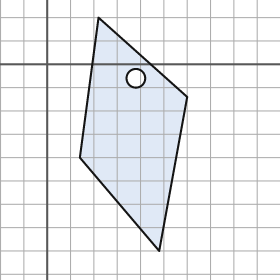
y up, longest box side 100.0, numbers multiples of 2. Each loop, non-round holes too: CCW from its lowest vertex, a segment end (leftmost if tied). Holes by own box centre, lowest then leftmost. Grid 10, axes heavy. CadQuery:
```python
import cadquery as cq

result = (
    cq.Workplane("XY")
    .moveTo(48.0, -80.0)
    .lineTo(60.0, -14.0)
    .lineTo(22.0, 20.0)
    .lineTo(14.0, -40.0)
    .close()
    .moveTo(38.0, -6.0)
    .circle(4.0)
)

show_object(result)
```